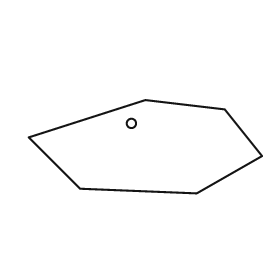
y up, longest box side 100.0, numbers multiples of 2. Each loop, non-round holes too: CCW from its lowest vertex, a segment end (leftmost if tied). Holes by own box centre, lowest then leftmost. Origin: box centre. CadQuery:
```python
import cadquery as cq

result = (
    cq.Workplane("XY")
    .moveTo(22.0, -20.0)
    .lineTo(50.0, -4.0)
    .lineTo(34.0, 16.0)
    .lineTo(0.0, 20.0)
    .lineTo(-50.0, 4.0)
    .lineTo(-28.0, -18.0)
    .close()
    .moveTo(-6.0, 10.0)
    .circle(2.0)
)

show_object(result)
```